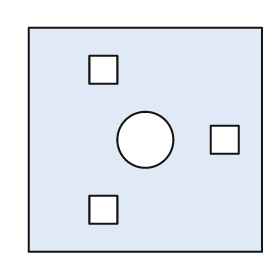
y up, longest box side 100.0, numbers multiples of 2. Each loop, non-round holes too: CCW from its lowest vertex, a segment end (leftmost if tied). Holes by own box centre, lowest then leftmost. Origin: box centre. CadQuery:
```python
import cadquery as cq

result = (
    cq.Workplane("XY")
    .moveTo(-50.0, -48.0)
    .lineTo(50.0, -48.0)
    .lineTo(50.0, 48.0)
    .lineTo(-50.0, 48.0)
    .close()
    .moveTo(-24.0, -36.0)
    .lineTo(-12.0, -36.0)
    .lineTo(-12.0, -24.0)
    .lineTo(-24.0, -24.0)
    .close()
    .moveTo(0.0, 0.0)
    .circle(12.0)
    .moveTo(28.0, -6.0)
    .lineTo(40.0, -6.0)
    .lineTo(40.0, 6.0)
    .lineTo(28.0, 6.0)
    .close()
    .moveTo(-24.0, 24.0)
    .lineTo(-12.0, 24.0)
    .lineTo(-12.0, 36.0)
    .lineTo(-24.0, 36.0)
    .close()
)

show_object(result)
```